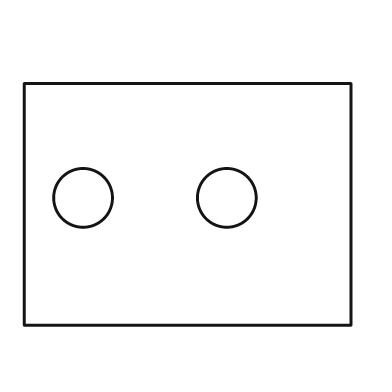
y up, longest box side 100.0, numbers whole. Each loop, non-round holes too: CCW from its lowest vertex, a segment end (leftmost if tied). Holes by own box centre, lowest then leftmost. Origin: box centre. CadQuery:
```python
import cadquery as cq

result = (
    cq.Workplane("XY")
    .moveTo(-50.0, -37.0)
    .lineTo(50.0, -37.0)
    .lineTo(50.0, 37.0)
    .lineTo(-50.0, 37.0)
    .close()
    .moveTo(-32.0, 2.0)
    .circle(9.0)
    .moveTo(12.0, 2.0)
    .circle(9.0)
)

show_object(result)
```